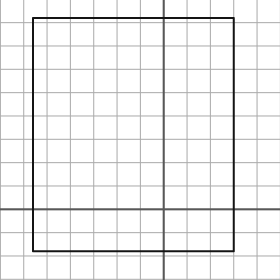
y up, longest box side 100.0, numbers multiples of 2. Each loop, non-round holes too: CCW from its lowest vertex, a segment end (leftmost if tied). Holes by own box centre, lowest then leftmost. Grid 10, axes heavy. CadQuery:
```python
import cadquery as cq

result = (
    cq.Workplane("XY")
    .moveTo(-56.0, -18.0)
    .lineTo(30.0, -18.0)
    .lineTo(30.0, 82.0)
    .lineTo(-56.0, 82.0)
    .close()
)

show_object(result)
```